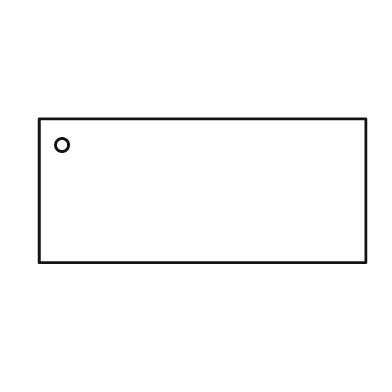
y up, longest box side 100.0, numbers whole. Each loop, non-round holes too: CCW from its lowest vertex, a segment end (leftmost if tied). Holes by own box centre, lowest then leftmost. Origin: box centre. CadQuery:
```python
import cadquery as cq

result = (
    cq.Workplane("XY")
    .moveTo(-50.0, -22.0)
    .lineTo(50.0, -22.0)
    .lineTo(50.0, 22.0)
    .lineTo(-50.0, 22.0)
    .close()
    .moveTo(-43.0, 14.0)
    .circle(2.0)
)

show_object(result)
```